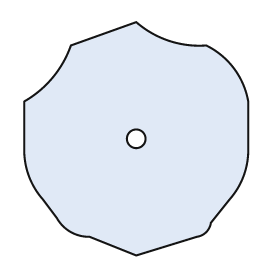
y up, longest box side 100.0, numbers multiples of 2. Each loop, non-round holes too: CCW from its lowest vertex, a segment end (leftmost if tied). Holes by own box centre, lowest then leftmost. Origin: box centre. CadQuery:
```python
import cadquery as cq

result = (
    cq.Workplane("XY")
    .moveTo(0.0, -50.0)
    .lineTo(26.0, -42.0)
    .threePointArc((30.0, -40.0), (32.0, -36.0))
    .lineTo(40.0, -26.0)
    .threePointArc((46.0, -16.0), (48.0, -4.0))
    .lineTo(48.0, 16.0)
    .threePointArc((42.0, 30.0), (30.0, 40.0))
    .threePointArc((14.0, 42.0), (0.0, 50.0))
    .lineTo(-28.0, 40.0)
    .threePointArc((-36.0, 26.0), (-48.0, 16.0))
    .lineTo(-48.0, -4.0)
    .threePointArc((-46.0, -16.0), (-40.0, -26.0))
    .lineTo(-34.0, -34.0)
    .threePointArc((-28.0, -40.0), (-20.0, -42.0))
    .close()
    .moveTo(0.0, 0.0)
    .circle(4.0)
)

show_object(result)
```